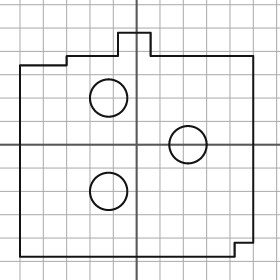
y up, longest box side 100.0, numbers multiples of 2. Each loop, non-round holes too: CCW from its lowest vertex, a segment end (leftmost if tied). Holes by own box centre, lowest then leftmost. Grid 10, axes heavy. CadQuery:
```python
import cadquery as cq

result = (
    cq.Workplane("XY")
    .moveTo(-50.0, -48.0)
    .lineTo(42.0, -48.0)
    .lineTo(42.0, -42.0)
    .lineTo(50.0, -42.0)
    .lineTo(50.0, 38.0)
    .lineTo(6.0, 38.0)
    .lineTo(6.0, 48.0)
    .lineTo(-8.0, 48.0)
    .lineTo(-8.0, 38.0)
    .lineTo(-30.0, 38.0)
    .lineTo(-30.0, 34.0)
    .lineTo(-50.0, 34.0)
    .close()
    .moveTo(-12.0, -20.0)
    .circle(8.0)
    .moveTo(22.0, 0.0)
    .circle(8.0)
    .moveTo(-12.0, 20.0)
    .circle(8.0)
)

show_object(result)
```